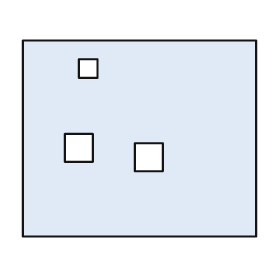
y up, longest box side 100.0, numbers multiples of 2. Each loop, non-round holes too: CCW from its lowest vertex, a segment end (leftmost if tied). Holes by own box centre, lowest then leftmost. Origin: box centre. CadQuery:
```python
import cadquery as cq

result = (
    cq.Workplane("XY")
    .moveTo(-50.0, -42.0)
    .lineTo(50.0, -42.0)
    .lineTo(50.0, 42.0)
    .lineTo(-50.0, 42.0)
    .close()
    .moveTo(-2.0, -14.0)
    .lineTo(10.0, -14.0)
    .lineTo(10.0, -2.0)
    .lineTo(-2.0, -2.0)
    .close()
    .moveTo(-32.0, -10.0)
    .lineTo(-20.0, -10.0)
    .lineTo(-20.0, 2.0)
    .lineTo(-32.0, 2.0)
    .close()
    .moveTo(-26.0, 26.0)
    .lineTo(-18.0, 26.0)
    .lineTo(-18.0, 34.0)
    .lineTo(-26.0, 34.0)
    .close()
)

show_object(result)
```